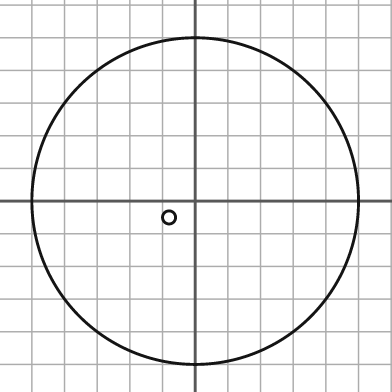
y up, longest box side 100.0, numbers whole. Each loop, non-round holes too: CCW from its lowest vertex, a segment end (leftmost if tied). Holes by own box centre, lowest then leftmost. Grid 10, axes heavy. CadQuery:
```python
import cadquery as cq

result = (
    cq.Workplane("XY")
    .moveTo(0.0, 0.0)
    .circle(50.0)
    .moveTo(-8.0, -5.0)
    .circle(2.0)
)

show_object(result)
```